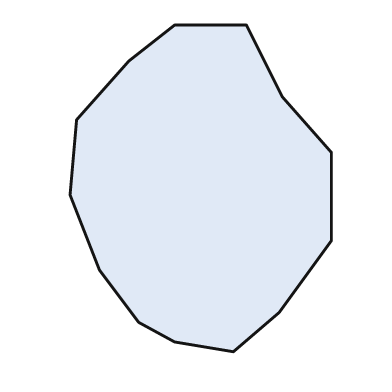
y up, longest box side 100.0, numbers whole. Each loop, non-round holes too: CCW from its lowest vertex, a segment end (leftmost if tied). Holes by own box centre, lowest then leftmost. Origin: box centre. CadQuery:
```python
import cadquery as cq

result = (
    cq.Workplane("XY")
    .moveTo(10.0, -50.0)
    .lineTo(24.0, -38.0)
    .lineTo(40.0, -16.0)
    .lineTo(40.0, 11.0)
    .lineTo(25.0, 28.0)
    .lineTo(14.0, 50.0)
    .lineTo(-8.0, 50.0)
    .lineTo(-22.0, 39.0)
    .lineTo(-38.0, 21.0)
    .lineTo(-40.0, -2.0)
    .lineTo(-31.0, -25.0)
    .lineTo(-19.0, -41.0)
    .lineTo(-8.0, -47.0)
    .close()
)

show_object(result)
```